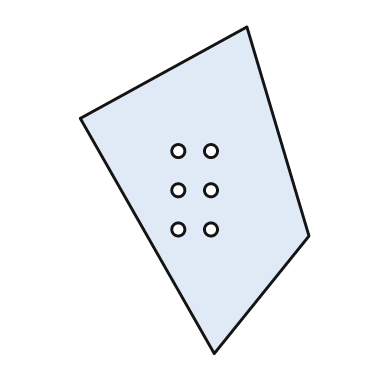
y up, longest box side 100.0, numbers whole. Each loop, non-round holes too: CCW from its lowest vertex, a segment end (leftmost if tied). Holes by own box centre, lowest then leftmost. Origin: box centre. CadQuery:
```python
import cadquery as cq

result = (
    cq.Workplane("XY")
    .moveTo(6.0, -50.0)
    .lineTo(35.0, -14.0)
    .lineTo(16.0, 50.0)
    .lineTo(-35.0, 22.0)
    .close()
    .moveTo(-5.0, -12.0)
    .circle(2.0)
    .moveTo(5.0, -12.0)
    .circle(2.0)
    .moveTo(-5.0, 0.0)
    .circle(2.0)
    .moveTo(5.0, 0.0)
    .circle(2.0)
    .moveTo(-5.0, 12.0)
    .circle(2.0)
    .moveTo(5.0, 12.0)
    .circle(2.0)
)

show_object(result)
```